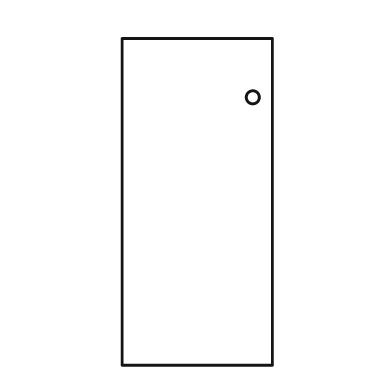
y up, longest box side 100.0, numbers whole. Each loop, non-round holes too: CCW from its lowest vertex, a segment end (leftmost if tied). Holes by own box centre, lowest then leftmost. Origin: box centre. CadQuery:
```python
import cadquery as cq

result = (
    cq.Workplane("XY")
    .moveTo(-23.0, -50.0)
    .lineTo(23.0, -50.0)
    .lineTo(23.0, 50.0)
    .lineTo(-23.0, 50.0)
    .close()
    .moveTo(17.0, 32.0)
    .circle(2.0)
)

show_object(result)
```